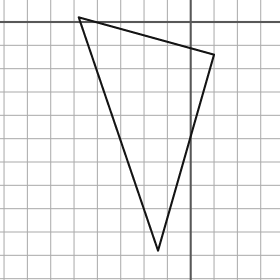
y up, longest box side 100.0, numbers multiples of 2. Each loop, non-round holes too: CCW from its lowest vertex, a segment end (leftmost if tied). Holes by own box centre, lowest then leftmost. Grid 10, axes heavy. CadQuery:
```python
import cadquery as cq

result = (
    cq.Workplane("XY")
    .moveTo(-14.0, -98.0)
    .lineTo(10.0, -14.0)
    .lineTo(-48.0, 2.0)
    .close()
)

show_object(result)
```